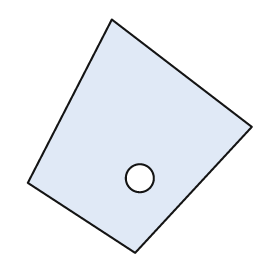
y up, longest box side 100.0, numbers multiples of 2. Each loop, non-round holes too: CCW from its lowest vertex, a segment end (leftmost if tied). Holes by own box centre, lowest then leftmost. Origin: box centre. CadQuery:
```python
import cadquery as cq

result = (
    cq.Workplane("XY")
    .moveTo(-2.0, -50.0)
    .lineTo(48.0, 4.0)
    .lineTo(-12.0, 50.0)
    .lineTo(-48.0, -20.0)
    .close()
    .moveTo(0.0, -18.0)
    .circle(6.0)
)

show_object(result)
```